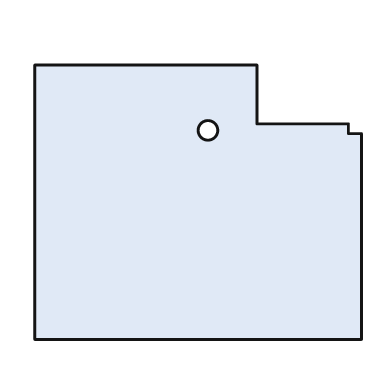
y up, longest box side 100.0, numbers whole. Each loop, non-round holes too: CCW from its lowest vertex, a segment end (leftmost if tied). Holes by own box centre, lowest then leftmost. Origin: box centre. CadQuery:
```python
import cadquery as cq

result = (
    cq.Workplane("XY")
    .moveTo(-50.0, -42.0)
    .lineTo(50.0, -42.0)
    .lineTo(50.0, 21.0)
    .lineTo(46.0, 21.0)
    .lineTo(46.0, 24.0)
    .lineTo(18.0, 24.0)
    .lineTo(18.0, 42.0)
    .lineTo(-50.0, 42.0)
    .close()
    .moveTo(3.0, 22.0)
    .circle(3.0)
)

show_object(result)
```